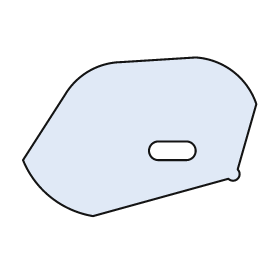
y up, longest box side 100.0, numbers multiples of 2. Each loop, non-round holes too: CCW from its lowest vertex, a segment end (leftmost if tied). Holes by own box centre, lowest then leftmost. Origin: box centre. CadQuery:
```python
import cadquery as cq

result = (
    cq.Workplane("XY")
    .moveTo(-20.0, -34.0)
    .lineTo(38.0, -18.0)
    .threePointArc((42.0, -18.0), (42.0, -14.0))
    .lineTo(50.0, 14.0)
    .threePointArc((40.0, 28.0), (24.0, 34.0))
    .lineTo(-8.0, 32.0)
    .threePointArc((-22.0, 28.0), (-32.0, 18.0))
    .lineTo(-50.0, -10.0)
    .threePointArc((-38.0, -26.0), (-20.0, -34.0))
    .close()
    .moveTo(8.0, -10.0)
    .lineTo(20.0, -10.0)
    .threePointArc((24.0, -6.0), (20.0, -2.0))
    .lineTo(8.0, -2.0)
    .threePointArc((4.0, -6.0), (8.0, -10.0))
    .close()
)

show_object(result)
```